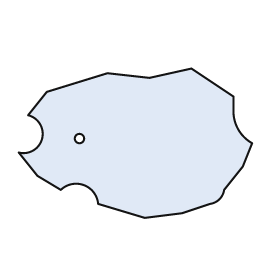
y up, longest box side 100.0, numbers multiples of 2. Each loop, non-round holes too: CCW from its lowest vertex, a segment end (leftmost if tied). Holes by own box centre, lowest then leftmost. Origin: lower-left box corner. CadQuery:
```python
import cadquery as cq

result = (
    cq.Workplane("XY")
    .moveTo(54.0, 0.0)
    .lineTo(70.0, 2.0)
    .lineTo(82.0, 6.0)
    .threePointArc((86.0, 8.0), (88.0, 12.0))
    .lineTo(96.0, 22.0)
    .lineTo(100.0, 32.0)
    .threePointArc((94.0, 38.0), (92.0, 46.0))
    .lineTo(92.0, 52.0)
    .lineTo(74.0, 64.0)
    .lineTo(56.0, 60.0)
    .lineTo(38.0, 62.0)
    .lineTo(12.0, 54.0)
    .lineTo(4.0, 44.0)
    .threePointArc((10.0, 34.0), (0.0, 28.0))
    .lineTo(8.0, 18.0)
    .lineTo(18.0, 12.0)
    .threePointArc((28.0, 14.0), (34.0, 6.0))
    .close()
    .moveTo(26.0, 34.0)
    .circle(2.0)
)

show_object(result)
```